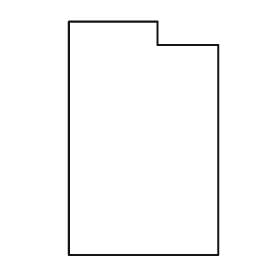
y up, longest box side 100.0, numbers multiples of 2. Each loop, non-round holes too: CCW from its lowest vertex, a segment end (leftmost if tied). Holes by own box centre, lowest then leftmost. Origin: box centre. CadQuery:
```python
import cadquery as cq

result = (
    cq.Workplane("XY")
    .moveTo(-32.0, -50.0)
    .lineTo(32.0, -50.0)
    .lineTo(32.0, 40.0)
    .lineTo(6.0, 40.0)
    .lineTo(6.0, 50.0)
    .lineTo(-32.0, 50.0)
    .close()
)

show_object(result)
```